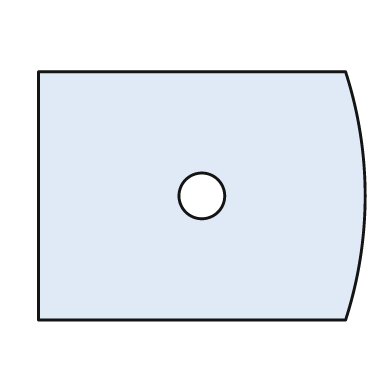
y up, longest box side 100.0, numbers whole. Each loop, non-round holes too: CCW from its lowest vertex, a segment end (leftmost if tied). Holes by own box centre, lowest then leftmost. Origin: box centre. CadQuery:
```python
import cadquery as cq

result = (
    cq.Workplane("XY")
    .moveTo(-50.0, -38.0)
    .lineTo(44.0, -38.0)
    .threePointArc((50.0, 0.0), (44.0, 38.0))
    .lineTo(-50.0, 38.0)
    .close()
    .moveTo(0.0, 0.0)
    .circle(7.0)
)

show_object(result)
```